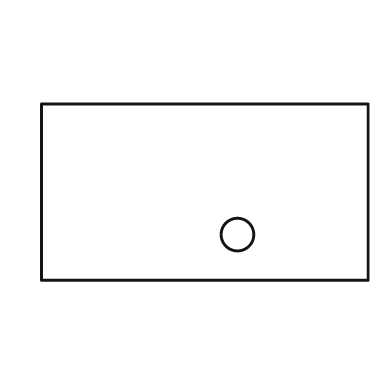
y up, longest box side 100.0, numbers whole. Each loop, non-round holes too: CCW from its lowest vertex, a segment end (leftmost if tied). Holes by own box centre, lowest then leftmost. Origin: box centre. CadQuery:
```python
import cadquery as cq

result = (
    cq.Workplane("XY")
    .moveTo(-50.0, -27.0)
    .lineTo(50.0, -27.0)
    .lineTo(50.0, 27.0)
    .lineTo(-50.0, 27.0)
    .close()
    .moveTo(10.0, -13.0)
    .circle(5.0)
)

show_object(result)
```